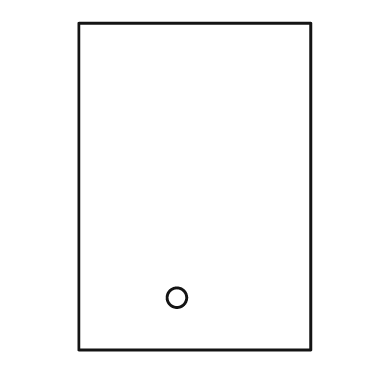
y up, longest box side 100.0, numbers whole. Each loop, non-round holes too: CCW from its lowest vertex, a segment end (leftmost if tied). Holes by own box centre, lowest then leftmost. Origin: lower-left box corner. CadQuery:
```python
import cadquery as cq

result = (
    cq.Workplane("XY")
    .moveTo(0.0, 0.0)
    .lineTo(71.0, 0.0)
    .lineTo(71.0, 100.0)
    .lineTo(0.0, 100.0)
    .close()
    .moveTo(30.0, 16.0)
    .circle(3.0)
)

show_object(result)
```